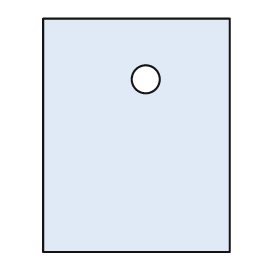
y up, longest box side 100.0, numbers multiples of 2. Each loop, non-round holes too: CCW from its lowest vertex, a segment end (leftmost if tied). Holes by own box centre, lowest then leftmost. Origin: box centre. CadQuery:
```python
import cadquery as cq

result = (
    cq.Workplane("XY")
    .moveTo(-40.0, -50.0)
    .lineTo(40.0, -50.0)
    .lineTo(40.0, 50.0)
    .lineTo(-40.0, 50.0)
    .close()
    .moveTo(4.0, 24.0)
    .circle(6.0)
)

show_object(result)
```